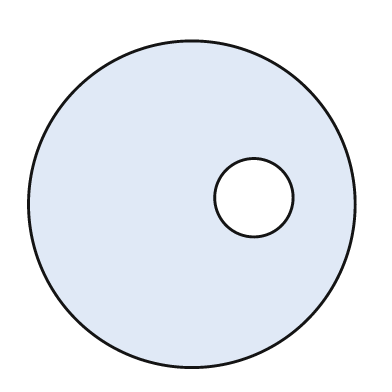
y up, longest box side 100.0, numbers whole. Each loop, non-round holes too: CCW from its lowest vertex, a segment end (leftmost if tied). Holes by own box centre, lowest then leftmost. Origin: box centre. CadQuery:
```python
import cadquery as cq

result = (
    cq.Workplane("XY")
    .moveTo(0.0, 0.0)
    .circle(50.0)
    .moveTo(19.0, 2.0)
    .circle(12.0)
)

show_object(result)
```